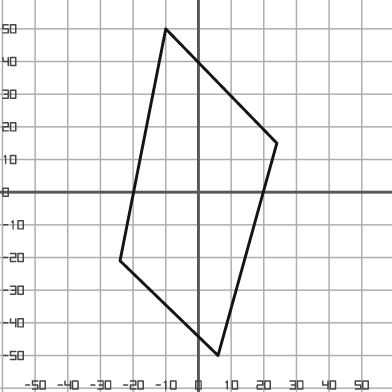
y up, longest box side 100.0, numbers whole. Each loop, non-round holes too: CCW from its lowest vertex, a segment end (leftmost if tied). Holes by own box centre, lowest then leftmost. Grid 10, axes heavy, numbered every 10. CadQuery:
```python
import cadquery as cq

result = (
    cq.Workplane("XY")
    .moveTo(6.0, -50.0)
    .lineTo(24.0, 15.0)
    .lineTo(-10.0, 50.0)
    .lineTo(-24.0, -21.0)
    .close()
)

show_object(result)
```